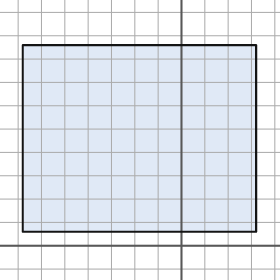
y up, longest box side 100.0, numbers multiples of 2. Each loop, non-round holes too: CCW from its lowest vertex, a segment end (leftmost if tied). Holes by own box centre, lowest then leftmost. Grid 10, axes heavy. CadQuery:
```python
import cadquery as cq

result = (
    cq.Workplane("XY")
    .moveTo(-68.0, 6.0)
    .lineTo(32.0, 6.0)
    .lineTo(32.0, 86.0)
    .lineTo(-68.0, 86.0)
    .close()
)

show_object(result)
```